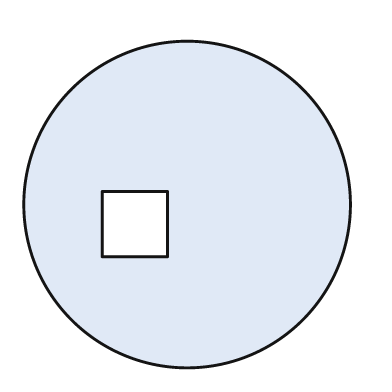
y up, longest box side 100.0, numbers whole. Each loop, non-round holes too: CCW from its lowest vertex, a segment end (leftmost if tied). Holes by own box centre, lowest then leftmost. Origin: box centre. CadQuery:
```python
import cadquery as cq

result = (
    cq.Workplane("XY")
    .moveTo(0.0, 0.0)
    .circle(50.0)
    .moveTo(-26.0, -16.0)
    .lineTo(-6.0, -16.0)
    .lineTo(-6.0, 4.0)
    .lineTo(-26.0, 4.0)
    .close()
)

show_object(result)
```